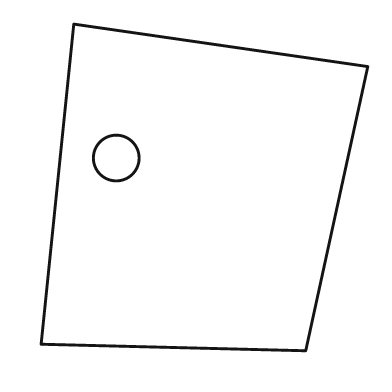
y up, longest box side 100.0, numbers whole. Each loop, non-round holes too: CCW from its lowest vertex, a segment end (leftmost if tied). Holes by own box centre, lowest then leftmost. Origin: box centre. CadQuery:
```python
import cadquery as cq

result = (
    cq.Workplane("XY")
    .moveTo(31.0, -50.0)
    .lineTo(50.0, 37.0)
    .lineTo(-40.0, 50.0)
    .lineTo(-50.0, -48.0)
    .close()
    .moveTo(-27.0, 9.0)
    .circle(7.0)
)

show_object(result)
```